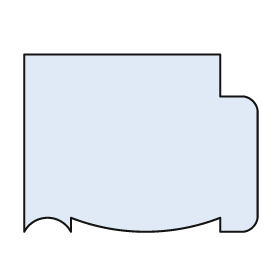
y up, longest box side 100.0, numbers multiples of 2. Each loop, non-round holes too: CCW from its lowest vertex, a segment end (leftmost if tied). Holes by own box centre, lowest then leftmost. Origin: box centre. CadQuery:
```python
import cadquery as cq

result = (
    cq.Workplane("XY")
    .moveTo(-50.0, -38.0)
    .threePointArc((-40.0, -32.0), (-30.0, -38.0))
    .lineTo(-30.0, -32.0)
    .threePointArc((2.0, -38.0), (34.0, -32.0))
    .lineTo(34.0, -38.0)
    .lineTo(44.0, -38.0)
    .threePointArc((48.0, -36.0), (50.0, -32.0))
    .lineTo(50.0, 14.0)
    .threePointArc((48.0, 18.0), (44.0, 20.0))
    .lineTo(34.0, 20.0)
    .lineTo(34.0, 38.0)
    .lineTo(-50.0, 38.0)
    .close()
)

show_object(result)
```